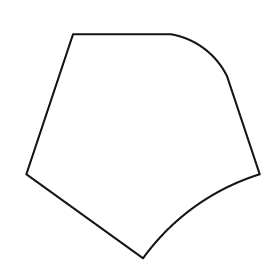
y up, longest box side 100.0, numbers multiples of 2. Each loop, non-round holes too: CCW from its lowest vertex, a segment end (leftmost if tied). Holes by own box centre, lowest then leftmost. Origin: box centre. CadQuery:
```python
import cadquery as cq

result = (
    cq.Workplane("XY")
    .moveTo(0.0, -48.0)
    .threePointArc((22.0, -26.0), (50.0, -12.0))
    .lineTo(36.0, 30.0)
    .threePointArc((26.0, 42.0), (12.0, 48.0))
    .lineTo(-30.0, 48.0)
    .lineTo(-50.0, -12.0)
    .close()
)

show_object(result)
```